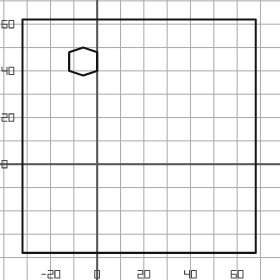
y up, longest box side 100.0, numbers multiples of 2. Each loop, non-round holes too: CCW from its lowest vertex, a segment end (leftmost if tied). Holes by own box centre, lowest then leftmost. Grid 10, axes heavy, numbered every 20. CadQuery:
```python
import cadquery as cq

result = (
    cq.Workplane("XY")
    .moveTo(-32.0, -38.0)
    .lineTo(68.0, -38.0)
    .lineTo(68.0, 62.0)
    .lineTo(-32.0, 62.0)
    .close()
    .moveTo(-6.0, 38.0)
    .lineTo(0.0, 40.0)
    .lineTo(0.0, 48.0)
    .lineTo(-6.0, 50.0)
    .lineTo(-12.0, 48.0)
    .lineTo(-12.0, 40.0)
    .close()
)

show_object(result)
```